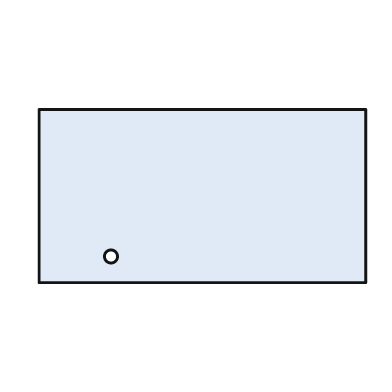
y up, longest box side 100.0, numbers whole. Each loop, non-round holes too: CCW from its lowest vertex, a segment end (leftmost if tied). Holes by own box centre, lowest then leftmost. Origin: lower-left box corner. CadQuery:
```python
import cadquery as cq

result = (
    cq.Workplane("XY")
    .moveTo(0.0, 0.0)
    .lineTo(100.0, 0.0)
    .lineTo(100.0, 53.0)
    .lineTo(0.0, 53.0)
    .close()
    .moveTo(22.0, 8.0)
    .circle(2.0)
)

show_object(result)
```